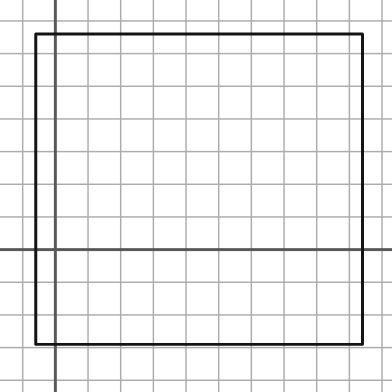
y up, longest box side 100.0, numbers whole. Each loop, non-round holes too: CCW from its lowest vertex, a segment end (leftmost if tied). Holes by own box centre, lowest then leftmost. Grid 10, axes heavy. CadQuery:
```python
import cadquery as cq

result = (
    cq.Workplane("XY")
    .moveTo(-6.0, -29.0)
    .lineTo(94.0, -29.0)
    .lineTo(94.0, 66.0)
    .lineTo(-6.0, 66.0)
    .close()
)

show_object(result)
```